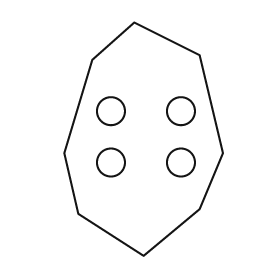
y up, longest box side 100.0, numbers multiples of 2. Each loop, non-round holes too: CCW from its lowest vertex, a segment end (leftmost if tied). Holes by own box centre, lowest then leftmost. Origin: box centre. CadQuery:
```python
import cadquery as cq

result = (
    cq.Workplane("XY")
    .moveTo(0.0, -50.0)
    .lineTo(24.0, -30.0)
    .lineTo(34.0, -6.0)
    .lineTo(24.0, 36.0)
    .lineTo(-4.0, 50.0)
    .lineTo(-22.0, 34.0)
    .lineTo(-34.0, -6.0)
    .lineTo(-28.0, -32.0)
    .close()
    .moveTo(-14.0, -10.0)
    .circle(6.0)
    .moveTo(16.0, -10.0)
    .circle(6.0)
    .moveTo(-14.0, 12.0)
    .circle(6.0)
    .moveTo(16.0, 12.0)
    .circle(6.0)
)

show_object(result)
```